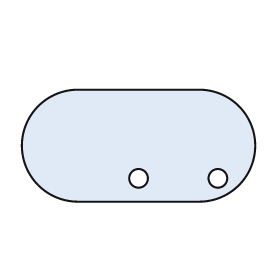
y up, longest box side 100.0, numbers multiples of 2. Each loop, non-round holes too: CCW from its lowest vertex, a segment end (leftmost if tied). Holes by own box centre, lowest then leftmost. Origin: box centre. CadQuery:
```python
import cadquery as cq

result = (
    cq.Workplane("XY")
    .moveTo(-26.0, -24.0)
    .lineTo(26.0, -24.0)
    .threePointArc((50.0, 0.0), (26.0, 24.0))
    .lineTo(-26.0, 24.0)
    .threePointArc((-50.0, 0.0), (-26.0, -24.0))
    .close()
    .moveTo(0.0, -14.0)
    .circle(4.0)
    .moveTo(34.0, -14.0)
    .circle(4.0)
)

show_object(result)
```